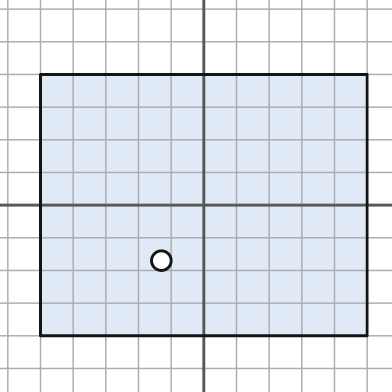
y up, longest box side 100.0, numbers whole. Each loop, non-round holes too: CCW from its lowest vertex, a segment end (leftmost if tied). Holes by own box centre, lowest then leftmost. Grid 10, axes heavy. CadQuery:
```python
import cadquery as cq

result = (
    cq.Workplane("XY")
    .moveTo(-50.0, -40.0)
    .lineTo(50.0, -40.0)
    .lineTo(50.0, 40.0)
    .lineTo(-50.0, 40.0)
    .close()
    .moveTo(-13.0, -17.0)
    .circle(3.0)
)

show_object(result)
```